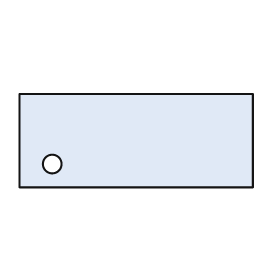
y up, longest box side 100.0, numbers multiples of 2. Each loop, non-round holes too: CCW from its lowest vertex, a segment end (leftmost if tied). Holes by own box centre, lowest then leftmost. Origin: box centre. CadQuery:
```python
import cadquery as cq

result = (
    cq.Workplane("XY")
    .moveTo(-50.0, -20.0)
    .lineTo(50.0, -20.0)
    .lineTo(50.0, 20.0)
    .lineTo(-50.0, 20.0)
    .close()
    .moveTo(-36.0, -10.0)
    .circle(4.0)
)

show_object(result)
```